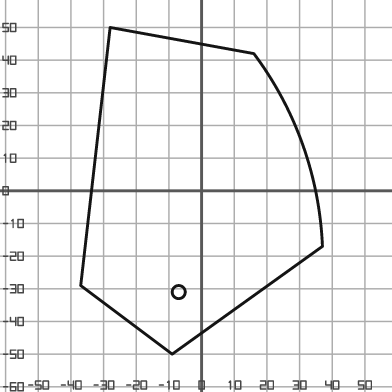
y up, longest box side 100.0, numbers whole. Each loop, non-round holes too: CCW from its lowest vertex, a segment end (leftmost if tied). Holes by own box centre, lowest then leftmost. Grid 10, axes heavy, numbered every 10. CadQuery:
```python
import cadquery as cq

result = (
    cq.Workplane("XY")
    .moveTo(-9.0, -50.0)
    .lineTo(37.0, -17.0)
    .threePointArc((31.0, 14.0), (16.0, 42.0))
    .lineTo(-28.0, 50.0)
    .lineTo(-37.0, -29.0)
    .close()
    .moveTo(-7.0, -31.0)
    .circle(2.0)
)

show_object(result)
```